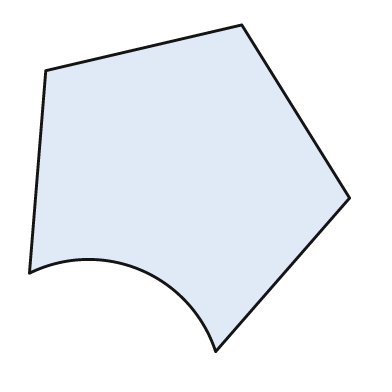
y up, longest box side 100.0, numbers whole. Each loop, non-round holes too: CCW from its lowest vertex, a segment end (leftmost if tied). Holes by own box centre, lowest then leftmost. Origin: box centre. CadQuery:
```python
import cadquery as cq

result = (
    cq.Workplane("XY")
    .moveTo(8.0, -50.0)
    .lineTo(49.0, -3.0)
    .lineTo(16.0, 50.0)
    .lineTo(-44.0, 36.0)
    .lineTo(-49.0, -26.0)
    .threePointArc((-15.0, -25.0), (8.0, -50.0))
    .close()
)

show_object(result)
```